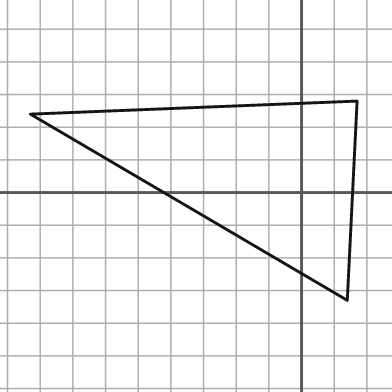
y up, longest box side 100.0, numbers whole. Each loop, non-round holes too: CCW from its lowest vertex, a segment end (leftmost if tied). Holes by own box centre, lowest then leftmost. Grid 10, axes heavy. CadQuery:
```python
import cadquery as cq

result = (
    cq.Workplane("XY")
    .moveTo(14.0, -33.0)
    .lineTo(17.0, 28.0)
    .lineTo(-83.0, 24.0)
    .close()
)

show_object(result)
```